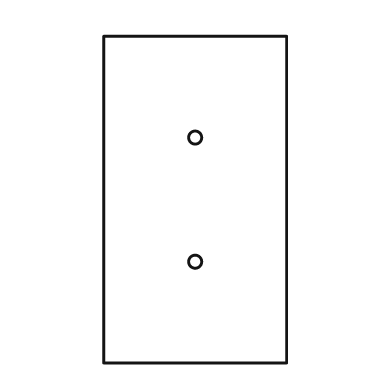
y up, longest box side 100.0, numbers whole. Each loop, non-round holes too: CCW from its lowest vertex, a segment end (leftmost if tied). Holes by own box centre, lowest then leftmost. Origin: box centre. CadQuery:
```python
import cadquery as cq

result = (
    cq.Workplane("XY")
    .moveTo(-28.0, -50.0)
    .lineTo(28.0, -50.0)
    .lineTo(28.0, 50.0)
    .lineTo(-28.0, 50.0)
    .close()
    .moveTo(0.0, -19.0)
    .circle(2.0)
    .moveTo(0.0, 19.0)
    .circle(2.0)
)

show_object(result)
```